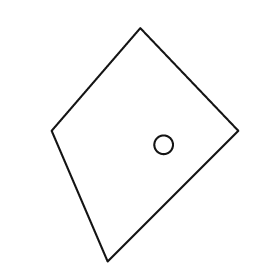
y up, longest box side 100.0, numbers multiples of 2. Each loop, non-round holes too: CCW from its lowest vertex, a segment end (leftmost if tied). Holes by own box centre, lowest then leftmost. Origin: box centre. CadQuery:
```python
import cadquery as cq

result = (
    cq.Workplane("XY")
    .moveTo(-16.0, -50.0)
    .lineTo(40.0, 6.0)
    .lineTo(-2.0, 50.0)
    .lineTo(-40.0, 6.0)
    .close()
    .moveTo(8.0, 0.0)
    .circle(4.0)
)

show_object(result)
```